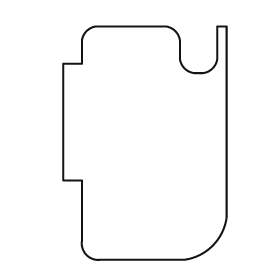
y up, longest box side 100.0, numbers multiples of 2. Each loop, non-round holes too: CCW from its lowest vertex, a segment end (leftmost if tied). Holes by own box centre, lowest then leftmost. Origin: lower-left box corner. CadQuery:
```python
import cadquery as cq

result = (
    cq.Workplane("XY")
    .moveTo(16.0, 0.0)
    .lineTo(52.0, 0.0)
    .threePointArc((64.0, 6.0), (70.0, 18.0))
    .lineTo(70.0, 100.0)
    .lineTo(66.0, 100.0)
    .lineTo(66.0, 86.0)
    .threePointArc((64.0, 82.0), (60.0, 80.0))
    .lineTo(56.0, 80.0)
    .threePointArc((52.0, 82.0), (50.0, 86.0))
    .lineTo(50.0, 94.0)
    .threePointArc((48.0, 98.0), (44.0, 100.0))
    .lineTo(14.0, 100.0)
    .threePointArc((10.0, 98.0), (8.0, 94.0))
    .lineTo(8.0, 84.0)
    .lineTo(0.0, 84.0)
    .lineTo(0.0, 34.0)
    .lineTo(8.0, 34.0)
    .lineTo(8.0, 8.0)
    .threePointArc((10.0, 2.0), (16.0, 0.0))
    .close()
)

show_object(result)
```